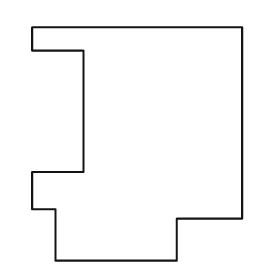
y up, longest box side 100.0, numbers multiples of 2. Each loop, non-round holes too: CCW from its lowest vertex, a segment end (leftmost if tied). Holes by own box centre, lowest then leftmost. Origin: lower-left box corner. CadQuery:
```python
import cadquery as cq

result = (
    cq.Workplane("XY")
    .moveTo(10.0, 0.0)
    .lineTo(62.0, 0.0)
    .lineTo(62.0, 18.0)
    .lineTo(90.0, 18.0)
    .lineTo(90.0, 100.0)
    .lineTo(0.0, 100.0)
    .lineTo(0.0, 90.0)
    .lineTo(22.0, 90.0)
    .lineTo(22.0, 38.0)
    .lineTo(0.0, 38.0)
    .lineTo(0.0, 22.0)
    .lineTo(10.0, 22.0)
    .close()
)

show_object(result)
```